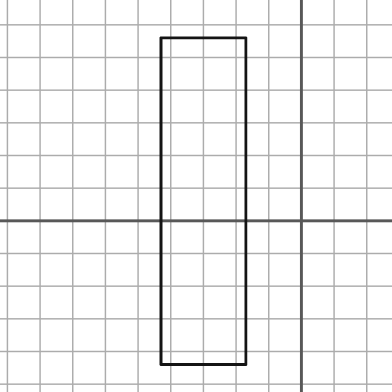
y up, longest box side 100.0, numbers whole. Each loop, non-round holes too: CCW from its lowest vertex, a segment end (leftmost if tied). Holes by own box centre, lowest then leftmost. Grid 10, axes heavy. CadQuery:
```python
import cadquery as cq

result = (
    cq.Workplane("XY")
    .moveTo(-43.0, -44.0)
    .lineTo(-17.0, -44.0)
    .lineTo(-17.0, 56.0)
    .lineTo(-43.0, 56.0)
    .close()
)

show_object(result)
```